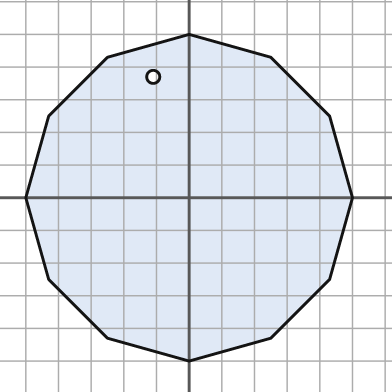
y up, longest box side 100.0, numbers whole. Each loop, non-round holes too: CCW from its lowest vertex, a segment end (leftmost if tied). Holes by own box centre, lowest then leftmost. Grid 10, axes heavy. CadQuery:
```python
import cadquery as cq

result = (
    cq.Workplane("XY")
    .moveTo(0.0, -50.0)
    .lineTo(25.0, -43.0)
    .lineTo(43.0, -25.0)
    .lineTo(50.0, 0.0)
    .lineTo(43.0, 25.0)
    .lineTo(25.0, 43.0)
    .lineTo(0.0, 50.0)
    .lineTo(-25.0, 43.0)
    .lineTo(-43.0, 25.0)
    .lineTo(-50.0, 0.0)
    .lineTo(-43.0, -25.0)
    .lineTo(-25.0, -43.0)
    .close()
    .moveTo(-11.0, 37.0)
    .circle(2.0)
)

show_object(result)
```